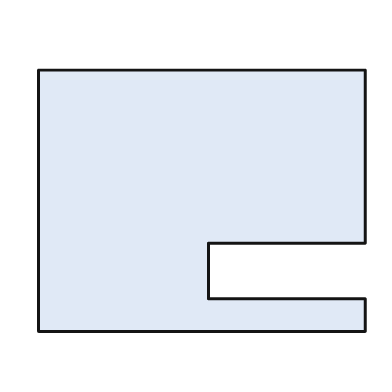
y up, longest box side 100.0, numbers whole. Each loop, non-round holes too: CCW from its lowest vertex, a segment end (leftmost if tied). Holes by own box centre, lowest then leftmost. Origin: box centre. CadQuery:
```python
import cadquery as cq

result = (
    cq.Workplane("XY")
    .moveTo(-50.0, -40.0)
    .lineTo(50.0, -40.0)
    .lineTo(50.0, -30.0)
    .lineTo(2.0, -30.0)
    .lineTo(2.0, -13.0)
    .lineTo(50.0, -13.0)
    .lineTo(50.0, 40.0)
    .lineTo(-50.0, 40.0)
    .close()
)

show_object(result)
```